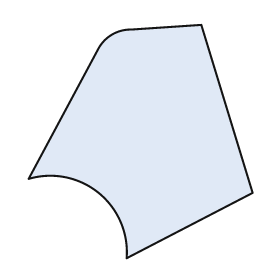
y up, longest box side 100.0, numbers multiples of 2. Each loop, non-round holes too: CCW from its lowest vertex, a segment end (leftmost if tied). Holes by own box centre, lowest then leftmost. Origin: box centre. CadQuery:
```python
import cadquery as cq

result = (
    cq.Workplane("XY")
    .moveTo(-6.0, -50.0)
    .lineTo(48.0, -22.0)
    .lineTo(26.0, 50.0)
    .lineTo(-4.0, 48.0)
    .threePointArc((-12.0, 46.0), (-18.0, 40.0))
    .lineTo(-48.0, -16.0)
    .threePointArc((-18.0, -22.0), (-6.0, -50.0))
    .close()
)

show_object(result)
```